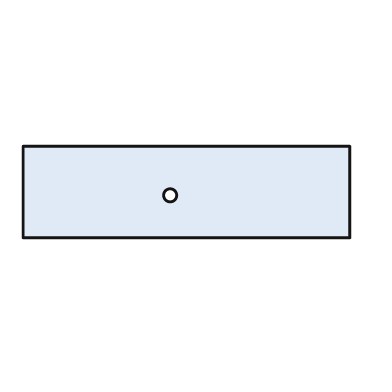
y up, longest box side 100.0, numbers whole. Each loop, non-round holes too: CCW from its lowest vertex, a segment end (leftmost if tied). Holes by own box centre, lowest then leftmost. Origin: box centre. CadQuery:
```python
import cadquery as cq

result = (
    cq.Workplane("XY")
    .moveTo(-50.0, -14.0)
    .lineTo(50.0, -14.0)
    .lineTo(50.0, 14.0)
    .lineTo(-50.0, 14.0)
    .close()
    .moveTo(-5.0, -1.0)
    .circle(2.0)
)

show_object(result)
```